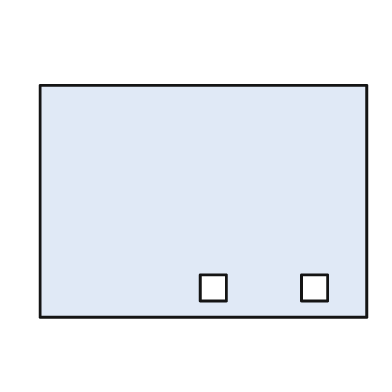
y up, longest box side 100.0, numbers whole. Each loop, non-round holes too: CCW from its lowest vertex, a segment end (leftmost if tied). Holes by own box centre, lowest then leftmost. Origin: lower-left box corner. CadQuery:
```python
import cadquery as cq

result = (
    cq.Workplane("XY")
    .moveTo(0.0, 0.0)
    .lineTo(100.0, 0.0)
    .lineTo(100.0, 71.0)
    .lineTo(0.0, 71.0)
    .close()
    .moveTo(49.0, 5.0)
    .lineTo(57.0, 5.0)
    .lineTo(57.0, 13.0)
    .lineTo(49.0, 13.0)
    .close()
    .moveTo(80.0, 5.0)
    .lineTo(88.0, 5.0)
    .lineTo(88.0, 13.0)
    .lineTo(80.0, 13.0)
    .close()
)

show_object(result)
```